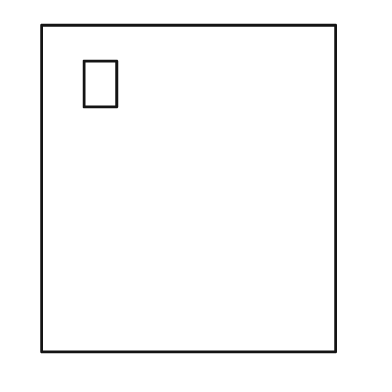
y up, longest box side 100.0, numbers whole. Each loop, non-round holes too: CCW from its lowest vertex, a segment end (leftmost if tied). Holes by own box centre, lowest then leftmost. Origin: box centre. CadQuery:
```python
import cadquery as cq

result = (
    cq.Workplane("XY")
    .moveTo(-45.0, -50.0)
    .lineTo(45.0, -50.0)
    .lineTo(45.0, 50.0)
    .lineTo(-45.0, 50.0)
    .close()
    .moveTo(-32.0, 25.0)
    .lineTo(-22.0, 25.0)
    .lineTo(-22.0, 39.0)
    .lineTo(-32.0, 39.0)
    .close()
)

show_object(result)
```